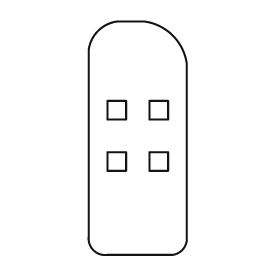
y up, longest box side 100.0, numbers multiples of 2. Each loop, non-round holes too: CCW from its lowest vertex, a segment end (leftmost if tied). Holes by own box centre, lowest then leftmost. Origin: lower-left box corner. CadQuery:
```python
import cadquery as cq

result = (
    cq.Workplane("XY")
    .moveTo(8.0, 0.0)
    .lineTo(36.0, 0.0)
    .threePointArc((40.0, 2.0), (42.0, 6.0))
    .lineTo(42.0, 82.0)
    .threePointArc((36.0, 94.0), (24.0, 100.0))
    .lineTo(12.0, 100.0)
    .threePointArc((4.0, 96.0), (0.0, 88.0))
    .lineTo(0.0, 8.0)
    .threePointArc((2.0, 2.0), (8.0, 0.0))
    .close()
    .moveTo(8.0, 36.0)
    .lineTo(16.0, 36.0)
    .lineTo(16.0, 44.0)
    .lineTo(8.0, 44.0)
    .close()
    .moveTo(26.0, 36.0)
    .lineTo(34.0, 36.0)
    .lineTo(34.0, 44.0)
    .lineTo(26.0, 44.0)
    .close()
    .moveTo(8.0, 58.0)
    .lineTo(16.0, 58.0)
    .lineTo(16.0, 66.0)
    .lineTo(8.0, 66.0)
    .close()
    .moveTo(26.0, 58.0)
    .lineTo(34.0, 58.0)
    .lineTo(34.0, 66.0)
    .lineTo(26.0, 66.0)
    .close()
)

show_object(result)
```